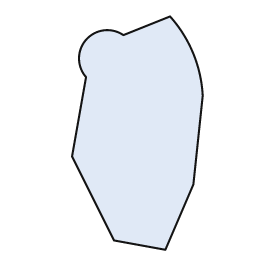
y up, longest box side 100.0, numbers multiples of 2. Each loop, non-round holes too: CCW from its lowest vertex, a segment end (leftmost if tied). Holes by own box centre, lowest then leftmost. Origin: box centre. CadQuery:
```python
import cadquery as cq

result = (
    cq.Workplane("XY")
    .moveTo(12.0, -50.0)
    .lineTo(24.0, -22.0)
    .lineTo(28.0, 16.0)
    .threePointArc((24.0, 34.0), (14.0, 50.0))
    .lineTo(-6.0, 42.0)
    .threePointArc((-22.0, 40.0), (-22.0, 24.0))
    .lineTo(-28.0, -10.0)
    .lineTo(-10.0, -46.0)
    .close()
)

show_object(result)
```